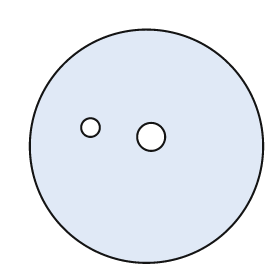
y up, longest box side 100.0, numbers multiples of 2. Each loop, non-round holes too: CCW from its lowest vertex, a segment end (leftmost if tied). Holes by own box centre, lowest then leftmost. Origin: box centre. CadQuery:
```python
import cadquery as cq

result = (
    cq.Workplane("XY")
    .moveTo(0.0, 0.0)
    .circle(50.0)
    .moveTo(2.0, 4.0)
    .circle(6.0)
    .moveTo(-24.0, 8.0)
    .circle(4.0)
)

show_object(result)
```